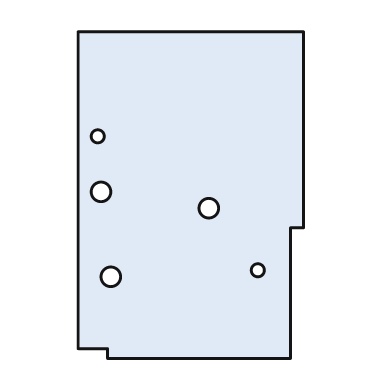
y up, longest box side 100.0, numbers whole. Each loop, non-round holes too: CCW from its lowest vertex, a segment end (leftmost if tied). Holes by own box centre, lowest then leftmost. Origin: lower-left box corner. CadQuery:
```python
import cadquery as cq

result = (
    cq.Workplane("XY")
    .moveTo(9.0, 0.0)
    .lineTo(65.0, 0.0)
    .lineTo(65.0, 40.0)
    .lineTo(69.0, 40.0)
    .lineTo(69.0, 100.0)
    .lineTo(0.0, 100.0)
    .lineTo(0.0, 3.0)
    .lineTo(9.0, 3.0)
    .close()
    .moveTo(10.0, 25.0)
    .circle(3.0)
    .moveTo(55.0, 27.0)
    .circle(2.0)
    .moveTo(40.0, 46.0)
    .circle(3.0)
    .moveTo(7.0, 51.0)
    .circle(3.0)
    .moveTo(6.0, 68.0)
    .circle(2.0)
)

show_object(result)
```